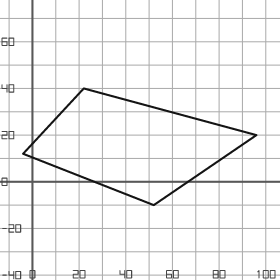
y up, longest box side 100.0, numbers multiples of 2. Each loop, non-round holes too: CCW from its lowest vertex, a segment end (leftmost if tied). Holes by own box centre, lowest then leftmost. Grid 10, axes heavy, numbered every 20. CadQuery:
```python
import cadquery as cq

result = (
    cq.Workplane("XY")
    .moveTo(52.0, -10.0)
    .lineTo(96.0, 20.0)
    .lineTo(22.0, 40.0)
    .lineTo(-4.0, 12.0)
    .close()
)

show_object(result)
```